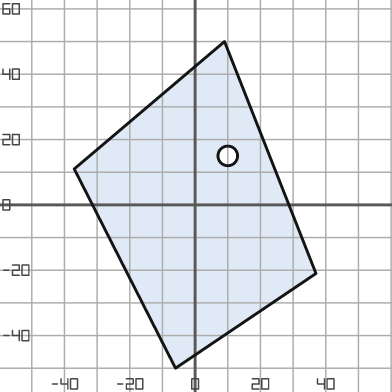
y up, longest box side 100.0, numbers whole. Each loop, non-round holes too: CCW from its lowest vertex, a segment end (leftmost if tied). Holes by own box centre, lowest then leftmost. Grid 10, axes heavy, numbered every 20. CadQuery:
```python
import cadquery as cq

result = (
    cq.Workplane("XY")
    .moveTo(-6.0, -50.0)
    .lineTo(37.0, -21.0)
    .lineTo(9.0, 50.0)
    .lineTo(-37.0, 11.0)
    .close()
    .moveTo(10.0, 15.0)
    .circle(3.0)
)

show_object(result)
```